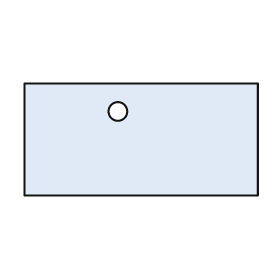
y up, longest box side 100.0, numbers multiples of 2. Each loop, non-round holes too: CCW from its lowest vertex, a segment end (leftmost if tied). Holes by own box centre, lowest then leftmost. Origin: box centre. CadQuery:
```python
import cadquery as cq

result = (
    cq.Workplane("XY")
    .moveTo(-50.0, -24.0)
    .lineTo(50.0, -24.0)
    .lineTo(50.0, 24.0)
    .lineTo(-50.0, 24.0)
    .close()
    .moveTo(-10.0, 12.0)
    .circle(4.0)
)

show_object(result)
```